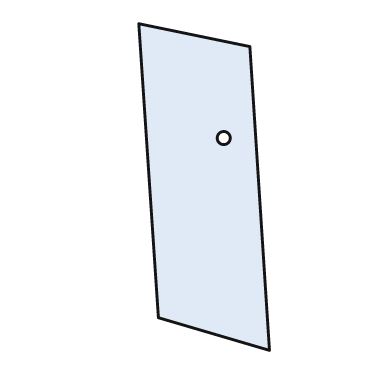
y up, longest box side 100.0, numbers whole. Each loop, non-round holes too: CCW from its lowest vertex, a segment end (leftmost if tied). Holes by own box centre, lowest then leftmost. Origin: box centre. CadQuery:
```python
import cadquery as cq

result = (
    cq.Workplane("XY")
    .moveTo(20.0, -50.0)
    .lineTo(14.0, 43.0)
    .lineTo(-20.0, 50.0)
    .lineTo(-14.0, -40.0)
    .close()
    .moveTo(6.0, 15.0)
    .circle(2.0)
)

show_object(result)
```